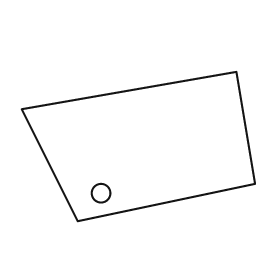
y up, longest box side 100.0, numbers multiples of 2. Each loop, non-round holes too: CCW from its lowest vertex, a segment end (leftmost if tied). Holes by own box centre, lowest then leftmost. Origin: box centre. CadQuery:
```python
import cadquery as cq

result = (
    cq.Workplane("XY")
    .moveTo(-26.0, -32.0)
    .lineTo(50.0, -16.0)
    .lineTo(42.0, 32.0)
    .lineTo(-50.0, 16.0)
    .close()
    .moveTo(-16.0, -20.0)
    .circle(4.0)
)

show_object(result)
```